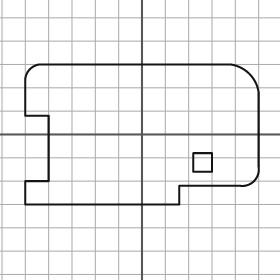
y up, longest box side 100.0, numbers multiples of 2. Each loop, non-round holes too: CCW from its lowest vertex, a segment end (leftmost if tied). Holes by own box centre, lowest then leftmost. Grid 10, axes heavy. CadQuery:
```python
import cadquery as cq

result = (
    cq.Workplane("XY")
    .moveTo(-50.0, -30.0)
    .lineTo(16.0, -30.0)
    .lineTo(16.0, -22.0)
    .lineTo(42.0, -22.0)
    .threePointArc((48.0, -20.0), (50.0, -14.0))
    .lineTo(50.0, 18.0)
    .threePointArc((46.0, 26.0), (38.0, 30.0))
    .lineTo(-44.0, 30.0)
    .threePointArc((-48.0, 28.0), (-50.0, 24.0))
    .lineTo(-50.0, 8.0)
    .lineTo(-40.0, 8.0)
    .lineTo(-40.0, -20.0)
    .lineTo(-50.0, -20.0)
    .close()
    .moveTo(22.0, -16.0)
    .lineTo(30.0, -16.0)
    .lineTo(30.0, -8.0)
    .lineTo(22.0, -8.0)
    .close()
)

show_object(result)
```